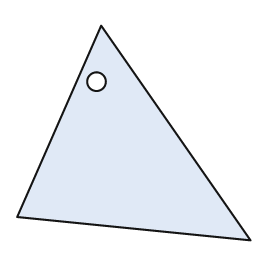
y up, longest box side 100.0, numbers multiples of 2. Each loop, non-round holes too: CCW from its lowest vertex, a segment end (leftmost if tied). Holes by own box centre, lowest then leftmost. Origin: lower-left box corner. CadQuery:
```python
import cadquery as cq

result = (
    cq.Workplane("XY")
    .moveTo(100.0, 0.0)
    .lineTo(36.0, 92.0)
    .lineTo(0.0, 10.0)
    .close()
    .moveTo(34.0, 68.0)
    .circle(4.0)
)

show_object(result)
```